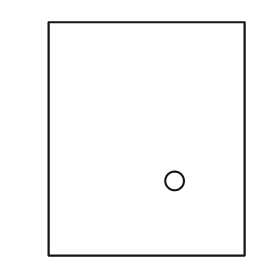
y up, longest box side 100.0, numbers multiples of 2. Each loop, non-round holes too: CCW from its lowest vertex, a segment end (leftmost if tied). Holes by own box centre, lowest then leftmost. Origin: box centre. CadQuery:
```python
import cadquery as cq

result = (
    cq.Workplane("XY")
    .moveTo(-42.0, -50.0)
    .lineTo(42.0, -50.0)
    .lineTo(42.0, 50.0)
    .lineTo(-42.0, 50.0)
    .close()
    .moveTo(12.0, -18.0)
    .circle(4.0)
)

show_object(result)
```